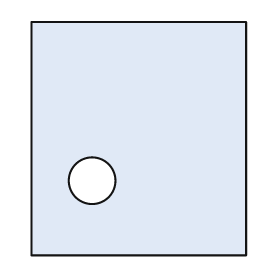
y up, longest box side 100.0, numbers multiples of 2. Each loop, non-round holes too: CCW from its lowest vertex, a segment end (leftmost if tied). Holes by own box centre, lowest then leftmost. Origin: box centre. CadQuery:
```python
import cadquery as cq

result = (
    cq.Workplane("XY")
    .moveTo(-46.0, -50.0)
    .lineTo(46.0, -50.0)
    .lineTo(46.0, 50.0)
    .lineTo(-46.0, 50.0)
    .close()
    .moveTo(-20.0, -18.0)
    .circle(10.0)
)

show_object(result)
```